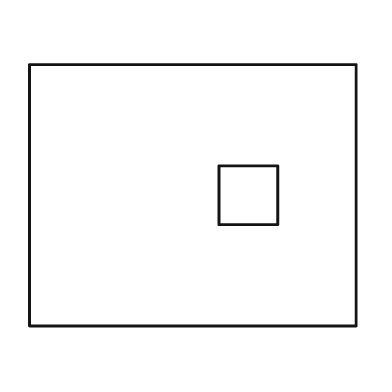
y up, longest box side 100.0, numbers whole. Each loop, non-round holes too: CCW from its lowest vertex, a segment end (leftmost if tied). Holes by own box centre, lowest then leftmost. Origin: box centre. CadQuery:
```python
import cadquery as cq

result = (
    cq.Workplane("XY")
    .moveTo(-50.0, -40.0)
    .lineTo(50.0, -40.0)
    .lineTo(50.0, 40.0)
    .lineTo(-50.0, 40.0)
    .close()
    .moveTo(8.0, -9.0)
    .lineTo(26.0, -9.0)
    .lineTo(26.0, 9.0)
    .lineTo(8.0, 9.0)
    .close()
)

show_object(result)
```